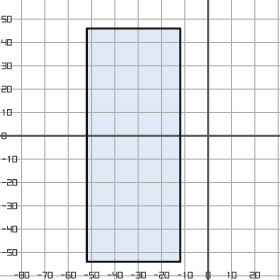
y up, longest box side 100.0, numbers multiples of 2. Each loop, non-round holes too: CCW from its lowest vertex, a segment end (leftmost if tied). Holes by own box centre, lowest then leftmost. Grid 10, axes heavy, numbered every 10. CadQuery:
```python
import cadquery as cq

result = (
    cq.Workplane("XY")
    .moveTo(-52.0, -54.0)
    .lineTo(-12.0, -54.0)
    .lineTo(-12.0, 46.0)
    .lineTo(-52.0, 46.0)
    .close()
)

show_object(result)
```